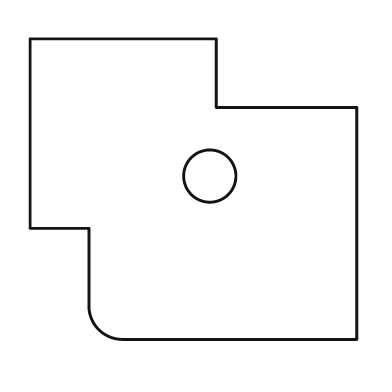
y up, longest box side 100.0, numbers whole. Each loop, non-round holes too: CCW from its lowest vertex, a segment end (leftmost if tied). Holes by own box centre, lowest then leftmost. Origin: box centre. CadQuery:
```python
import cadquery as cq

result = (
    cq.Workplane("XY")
    .moveTo(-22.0, -46.0)
    .lineTo(50.0, -46.0)
    .lineTo(50.0, 25.0)
    .lineTo(7.0, 25.0)
    .lineTo(7.0, 46.0)
    .lineTo(-50.0, 46.0)
    .lineTo(-50.0, -12.0)
    .lineTo(-32.0, -12.0)
    .lineTo(-32.0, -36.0)
    .threePointArc((-29.0, -43.0), (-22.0, -46.0))
    .close()
    .moveTo(5.0, 4.0)
    .circle(8.0)
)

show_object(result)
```